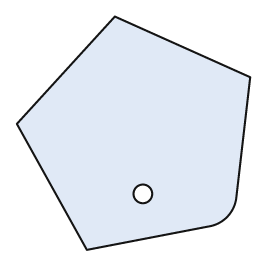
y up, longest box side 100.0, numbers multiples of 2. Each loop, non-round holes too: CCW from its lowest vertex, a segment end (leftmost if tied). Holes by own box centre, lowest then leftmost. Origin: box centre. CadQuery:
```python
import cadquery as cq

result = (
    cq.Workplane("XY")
    .moveTo(-20.0, -50.0)
    .lineTo(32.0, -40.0)
    .threePointArc((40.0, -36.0), (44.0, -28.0))
    .lineTo(50.0, 24.0)
    .lineTo(-8.0, 50.0)
    .lineTo(-50.0, 4.0)
    .close()
    .moveTo(4.0, -26.0)
    .circle(4.0)
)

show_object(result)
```